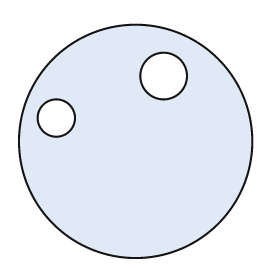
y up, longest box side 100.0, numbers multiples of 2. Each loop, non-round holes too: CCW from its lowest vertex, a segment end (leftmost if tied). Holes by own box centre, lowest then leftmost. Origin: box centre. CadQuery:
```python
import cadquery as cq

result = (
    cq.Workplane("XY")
    .moveTo(0.0, 0.0)
    .circle(50.0)
    .moveTo(-34.0, 10.0)
    .circle(8.0)
    .moveTo(12.0, 28.0)
    .circle(10.0)
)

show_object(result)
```